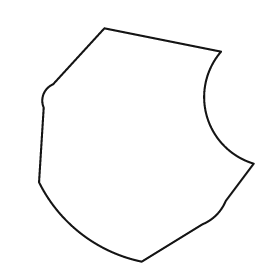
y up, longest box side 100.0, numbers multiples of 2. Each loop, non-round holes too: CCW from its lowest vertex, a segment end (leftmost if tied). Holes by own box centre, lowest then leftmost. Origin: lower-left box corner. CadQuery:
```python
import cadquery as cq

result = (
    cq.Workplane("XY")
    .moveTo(44.0, 0.0)
    .lineTo(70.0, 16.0)
    .threePointArc((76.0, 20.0), (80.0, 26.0))
    .lineTo(92.0, 42.0)
    .threePointArc((72.0, 62.0), (78.0, 90.0))
    .lineTo(28.0, 100.0)
    .lineTo(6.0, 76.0)
    .threePointArc((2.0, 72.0), (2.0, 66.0))
    .lineTo(0.0, 34.0)
    .threePointArc((18.0, 12.0), (44.0, 0.0))
    .close()
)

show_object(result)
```